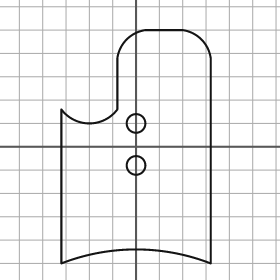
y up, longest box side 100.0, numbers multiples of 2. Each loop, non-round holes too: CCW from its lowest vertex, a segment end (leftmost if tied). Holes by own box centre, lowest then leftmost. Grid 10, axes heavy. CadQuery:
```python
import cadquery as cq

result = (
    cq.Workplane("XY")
    .moveTo(-32.0, -50.0)
    .threePointArc((0.0, -44.0), (32.0, -50.0))
    .lineTo(32.0, 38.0)
    .threePointArc((28.0, 46.0), (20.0, 50.0))
    .lineTo(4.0, 50.0)
    .threePointArc((-4.0, 46.0), (-8.0, 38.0))
    .lineTo(-8.0, 16.0)
    .threePointArc((-20.0, 10.0), (-32.0, 16.0))
    .close()
    .moveTo(0.0, -8.0)
    .circle(4.0)
    .moveTo(0.0, 10.0)
    .circle(4.0)
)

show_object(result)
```